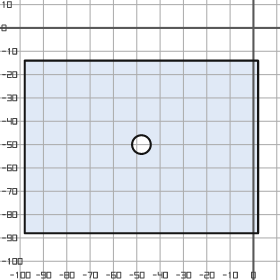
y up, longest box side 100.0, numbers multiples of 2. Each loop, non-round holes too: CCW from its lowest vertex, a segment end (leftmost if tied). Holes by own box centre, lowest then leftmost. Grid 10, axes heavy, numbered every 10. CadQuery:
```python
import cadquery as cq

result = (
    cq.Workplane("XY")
    .moveTo(-98.0, -88.0)
    .lineTo(2.0, -88.0)
    .lineTo(2.0, -14.0)
    .lineTo(-98.0, -14.0)
    .close()
    .moveTo(-48.0, -50.0)
    .circle(4.0)
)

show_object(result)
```